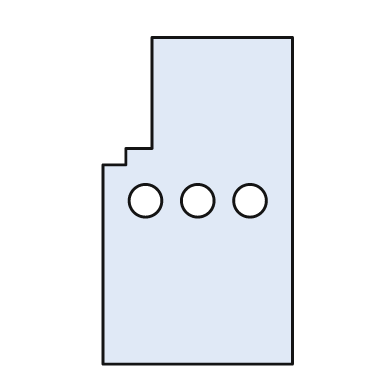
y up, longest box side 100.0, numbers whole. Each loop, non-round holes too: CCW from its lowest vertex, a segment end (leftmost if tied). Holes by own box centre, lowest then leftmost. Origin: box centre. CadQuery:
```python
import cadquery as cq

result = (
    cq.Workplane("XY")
    .moveTo(-29.0, -50.0)
    .lineTo(29.0, -50.0)
    .lineTo(29.0, 50.0)
    .lineTo(-14.0, 50.0)
    .lineTo(-14.0, 16.0)
    .lineTo(-22.0, 16.0)
    .lineTo(-22.0, 11.0)
    .lineTo(-29.0, 11.0)
    .close()
    .moveTo(-16.0, 0.0)
    .circle(5.0)
    .moveTo(0.0, 0.0)
    .circle(5.0)
    .moveTo(16.0, 0.0)
    .circle(5.0)
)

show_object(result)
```